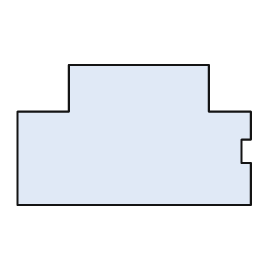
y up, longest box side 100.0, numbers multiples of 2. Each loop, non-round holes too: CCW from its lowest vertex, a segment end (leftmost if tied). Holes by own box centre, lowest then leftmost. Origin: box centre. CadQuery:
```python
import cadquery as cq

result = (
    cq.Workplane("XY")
    .moveTo(-50.0, -30.0)
    .lineTo(50.0, -30.0)
    .lineTo(50.0, -12.0)
    .lineTo(46.0, -12.0)
    .lineTo(46.0, -2.0)
    .lineTo(50.0, -2.0)
    .lineTo(50.0, 10.0)
    .lineTo(32.0, 10.0)
    .lineTo(32.0, 30.0)
    .lineTo(-28.0, 30.0)
    .lineTo(-28.0, 10.0)
    .lineTo(-50.0, 10.0)
    .close()
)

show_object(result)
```